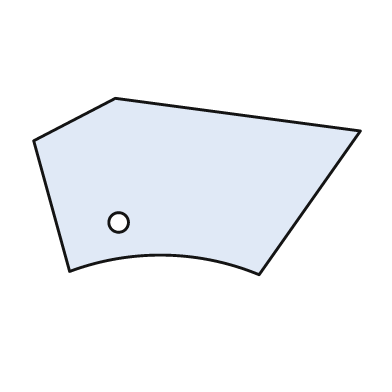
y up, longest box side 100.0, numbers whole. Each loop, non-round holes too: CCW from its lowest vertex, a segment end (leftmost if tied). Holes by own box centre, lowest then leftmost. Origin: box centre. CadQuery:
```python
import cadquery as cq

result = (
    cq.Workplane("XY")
    .moveTo(19.0, -27.0)
    .lineTo(50.0, 17.0)
    .lineTo(-25.0, 27.0)
    .lineTo(-50.0, 14.0)
    .lineTo(-39.0, -26.0)
    .threePointArc((-10.0, -21.0), (19.0, -27.0))
    .close()
    .moveTo(-24.0, -11.0)
    .circle(3.0)
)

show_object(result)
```